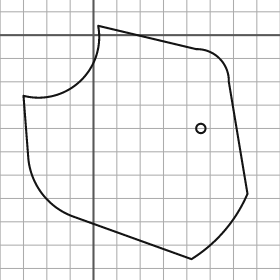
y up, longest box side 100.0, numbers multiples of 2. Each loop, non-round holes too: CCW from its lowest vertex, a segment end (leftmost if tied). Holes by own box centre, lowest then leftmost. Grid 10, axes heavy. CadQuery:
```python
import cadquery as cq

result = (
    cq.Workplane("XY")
    .moveTo(42.0, -96.0)
    .threePointArc((56.0, -84.0), (66.0, -68.0))
    .lineTo(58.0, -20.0)
    .threePointArc((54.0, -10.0), (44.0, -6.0))
    .lineTo(2.0, 4.0)
    .threePointArc((-6.0, -20.0), (-30.0, -26.0))
    .lineTo(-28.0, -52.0)
    .threePointArc((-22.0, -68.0), (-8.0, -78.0))
    .close()
    .moveTo(46.0, -40.0)
    .circle(2.0)
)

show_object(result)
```